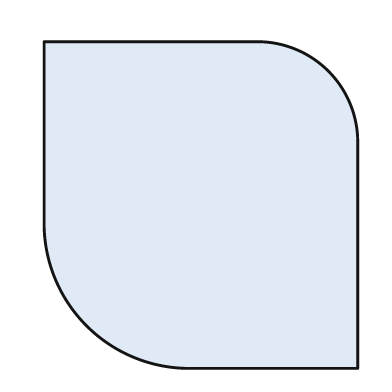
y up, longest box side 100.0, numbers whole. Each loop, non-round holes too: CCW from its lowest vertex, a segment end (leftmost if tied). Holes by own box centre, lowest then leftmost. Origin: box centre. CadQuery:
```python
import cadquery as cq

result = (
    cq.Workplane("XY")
    .moveTo(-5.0, -50.0)
    .lineTo(48.0, -50.0)
    .lineTo(48.0, 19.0)
    .threePointArc((39.0, 41.0), (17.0, 50.0))
    .lineTo(-48.0, 50.0)
    .lineTo(-48.0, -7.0)
    .threePointArc((-35.0, -37.0), (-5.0, -50.0))
    .close()
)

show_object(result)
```